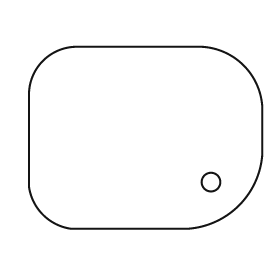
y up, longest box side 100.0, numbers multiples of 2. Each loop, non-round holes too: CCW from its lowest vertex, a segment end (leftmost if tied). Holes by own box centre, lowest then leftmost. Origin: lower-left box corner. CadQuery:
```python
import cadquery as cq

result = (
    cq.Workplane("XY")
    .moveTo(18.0, 0.0)
    .lineTo(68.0, 0.0)
    .threePointArc((90.0, 10.0), (100.0, 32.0))
    .lineTo(100.0, 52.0)
    .threePointArc((92.0, 70.0), (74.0, 78.0))
    .lineTo(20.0, 78.0)
    .threePointArc((6.0, 72.0), (0.0, 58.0))
    .lineTo(0.0, 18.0)
    .threePointArc((6.0, 6.0), (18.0, 0.0))
    .close()
    .moveTo(78.0, 20.0)
    .circle(4.0)
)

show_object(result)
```